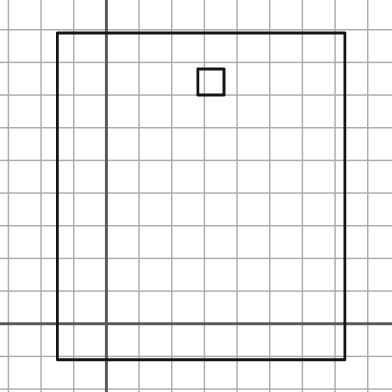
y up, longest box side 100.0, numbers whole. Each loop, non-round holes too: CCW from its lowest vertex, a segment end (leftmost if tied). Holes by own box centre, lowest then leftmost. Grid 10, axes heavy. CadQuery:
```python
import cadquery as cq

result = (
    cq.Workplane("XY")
    .moveTo(-15.0, -11.0)
    .lineTo(73.0, -11.0)
    .lineTo(73.0, 89.0)
    .lineTo(-15.0, 89.0)
    .close()
    .moveTo(28.0, 70.0)
    .lineTo(36.0, 70.0)
    .lineTo(36.0, 78.0)
    .lineTo(28.0, 78.0)
    .close()
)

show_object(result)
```